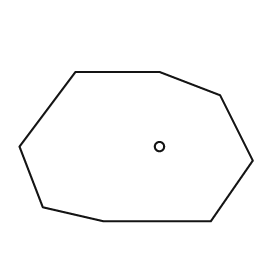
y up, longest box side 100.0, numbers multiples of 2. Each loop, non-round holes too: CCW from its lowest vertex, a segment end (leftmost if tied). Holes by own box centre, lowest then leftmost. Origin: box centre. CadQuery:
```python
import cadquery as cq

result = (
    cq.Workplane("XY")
    .moveTo(-14.0, -32.0)
    .lineTo(32.0, -32.0)
    .lineTo(50.0, -6.0)
    .lineTo(36.0, 22.0)
    .lineTo(10.0, 32.0)
    .lineTo(-26.0, 32.0)
    .lineTo(-50.0, 0.0)
    .lineTo(-40.0, -26.0)
    .close()
    .moveTo(10.0, 0.0)
    .circle(2.0)
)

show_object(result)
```